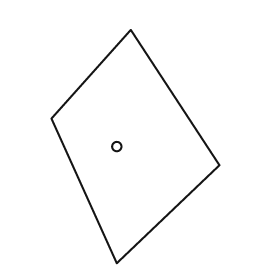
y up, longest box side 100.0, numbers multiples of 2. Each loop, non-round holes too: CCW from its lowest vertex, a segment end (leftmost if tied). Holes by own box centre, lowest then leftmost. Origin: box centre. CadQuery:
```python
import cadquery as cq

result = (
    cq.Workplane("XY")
    .moveTo(-8.0, -50.0)
    .lineTo(36.0, -8.0)
    .lineTo(-2.0, 50.0)
    .lineTo(-36.0, 12.0)
    .close()
    .moveTo(-8.0, 0.0)
    .circle(2.0)
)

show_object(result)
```